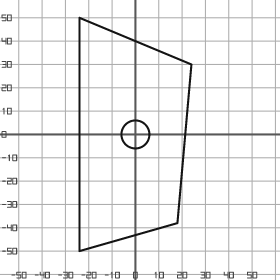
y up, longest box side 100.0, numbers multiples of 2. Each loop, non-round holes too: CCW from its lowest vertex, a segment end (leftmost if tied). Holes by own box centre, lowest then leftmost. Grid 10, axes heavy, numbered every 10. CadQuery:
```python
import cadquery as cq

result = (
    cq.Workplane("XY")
    .moveTo(-24.0, -50.0)
    .lineTo(18.0, -38.0)
    .lineTo(24.0, 30.0)
    .lineTo(-24.0, 50.0)
    .close()
    .moveTo(0.0, 0.0)
    .circle(6.0)
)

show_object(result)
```